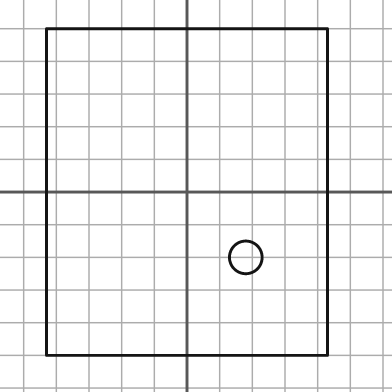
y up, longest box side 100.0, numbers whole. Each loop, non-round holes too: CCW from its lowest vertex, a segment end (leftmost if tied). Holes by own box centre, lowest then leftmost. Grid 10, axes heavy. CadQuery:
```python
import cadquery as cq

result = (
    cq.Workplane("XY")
    .moveTo(-43.0, -50.0)
    .lineTo(43.0, -50.0)
    .lineTo(43.0, 50.0)
    .lineTo(-43.0, 50.0)
    .close()
    .moveTo(18.0, -20.0)
    .circle(5.0)
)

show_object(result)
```